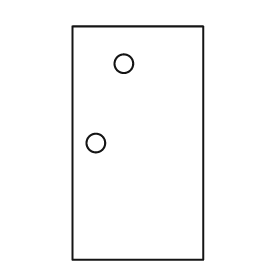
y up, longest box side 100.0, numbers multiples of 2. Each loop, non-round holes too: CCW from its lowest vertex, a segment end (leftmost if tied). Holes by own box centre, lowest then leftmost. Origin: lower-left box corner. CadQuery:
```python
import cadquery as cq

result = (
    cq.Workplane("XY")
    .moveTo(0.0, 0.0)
    .lineTo(56.0, 0.0)
    .lineTo(56.0, 100.0)
    .lineTo(0.0, 100.0)
    .close()
    .moveTo(10.0, 50.0)
    .circle(4.0)
    .moveTo(22.0, 84.0)
    .circle(4.0)
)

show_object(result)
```